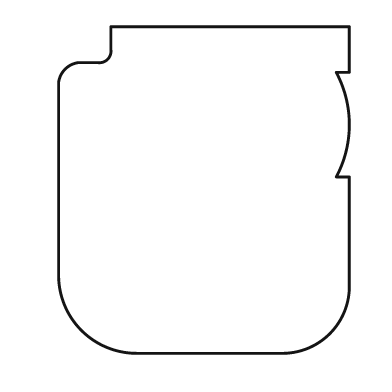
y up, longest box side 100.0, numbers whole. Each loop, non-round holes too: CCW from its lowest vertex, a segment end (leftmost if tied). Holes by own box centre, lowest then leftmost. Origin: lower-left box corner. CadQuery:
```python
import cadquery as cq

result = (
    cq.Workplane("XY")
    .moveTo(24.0, 0.0)
    .lineTo(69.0, 0.0)
    .threePointArc((83.0, 6.0), (89.0, 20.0))
    .lineTo(89.0, 54.0)
    .lineTo(85.0, 54.0)
    .threePointArc((89.0, 70.0), (85.0, 86.0))
    .lineTo(89.0, 86.0)
    .lineTo(89.0, 100.0)
    .lineTo(16.0, 100.0)
    .lineTo(16.0, 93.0)
    .threePointArc((15.0, 90.0), (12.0, 89.0))
    .lineTo(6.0, 89.0)
    .threePointArc((2.0, 87.0), (0.0, 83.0))
    .lineTo(0.0, 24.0)
    .threePointArc((7.0, 7.0), (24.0, 0.0))
    .close()
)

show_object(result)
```